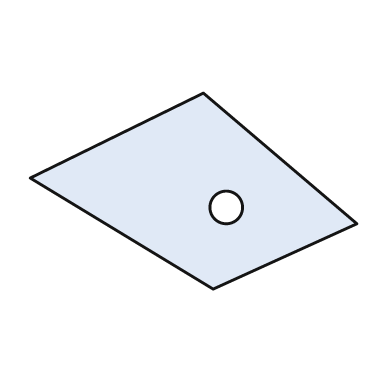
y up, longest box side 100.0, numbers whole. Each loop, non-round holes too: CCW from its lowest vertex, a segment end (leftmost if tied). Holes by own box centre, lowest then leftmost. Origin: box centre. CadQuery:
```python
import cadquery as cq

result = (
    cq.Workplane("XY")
    .moveTo(6.0, -30.0)
    .lineTo(50.0, -10.0)
    .lineTo(3.0, 30.0)
    .lineTo(-50.0, 4.0)
    .close()
    .moveTo(10.0, -5.0)
    .circle(5.0)
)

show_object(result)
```